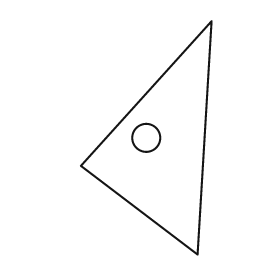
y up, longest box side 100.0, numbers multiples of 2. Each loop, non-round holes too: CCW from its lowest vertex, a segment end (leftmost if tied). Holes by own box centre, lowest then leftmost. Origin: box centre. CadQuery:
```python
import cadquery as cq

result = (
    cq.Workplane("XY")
    .moveTo(22.0, -50.0)
    .lineTo(28.0, 50.0)
    .lineTo(-28.0, -12.0)
    .close()
    .moveTo(0.0, 0.0)
    .circle(6.0)
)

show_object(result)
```